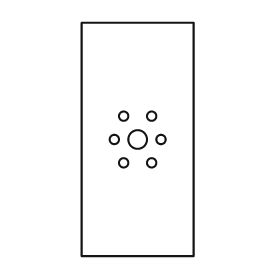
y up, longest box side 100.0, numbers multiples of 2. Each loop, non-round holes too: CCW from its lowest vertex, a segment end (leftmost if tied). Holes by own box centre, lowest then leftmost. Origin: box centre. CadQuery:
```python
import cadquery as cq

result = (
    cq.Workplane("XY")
    .moveTo(-24.0, -50.0)
    .lineTo(24.0, -50.0)
    .lineTo(24.0, 50.0)
    .lineTo(-24.0, 50.0)
    .close()
    .moveTo(-6.0, -10.0)
    .circle(2.0)
    .moveTo(6.0, -10.0)
    .circle(2.0)
    .moveTo(-10.0, 0.0)
    .circle(2.0)
    .moveTo(0.0, 0.0)
    .circle(4.0)
    .moveTo(10.0, 0.0)
    .circle(2.0)
    .moveTo(-6.0, 10.0)
    .circle(2.0)
    .moveTo(6.0, 10.0)
    .circle(2.0)
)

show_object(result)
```